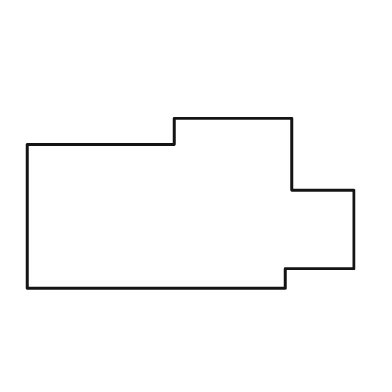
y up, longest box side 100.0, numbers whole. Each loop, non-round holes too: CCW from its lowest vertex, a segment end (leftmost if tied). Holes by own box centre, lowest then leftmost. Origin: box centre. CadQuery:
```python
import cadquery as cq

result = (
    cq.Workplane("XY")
    .moveTo(-50.0, -26.0)
    .lineTo(29.0, -26.0)
    .lineTo(29.0, -20.0)
    .lineTo(50.0, -20.0)
    .lineTo(50.0, 4.0)
    .lineTo(31.0, 4.0)
    .lineTo(31.0, 26.0)
    .lineTo(-5.0, 26.0)
    .lineTo(-5.0, 18.0)
    .lineTo(-50.0, 18.0)
    .close()
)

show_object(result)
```